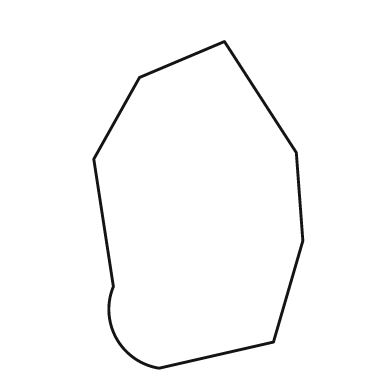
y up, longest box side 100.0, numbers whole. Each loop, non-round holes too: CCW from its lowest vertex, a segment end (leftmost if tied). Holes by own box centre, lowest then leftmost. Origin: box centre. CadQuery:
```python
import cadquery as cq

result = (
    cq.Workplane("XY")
    .moveTo(-12.0, -50.0)
    .lineTo(23.0, -42.0)
    .lineTo(32.0, -11.0)
    .lineTo(30.0, 16.0)
    .lineTo(8.0, 50.0)
    .lineTo(-18.0, 39.0)
    .lineTo(-32.0, 14.0)
    .lineTo(-26.0, -25.0)
    .threePointArc((-25.0, -41.0), (-12.0, -50.0))
    .close()
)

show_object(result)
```